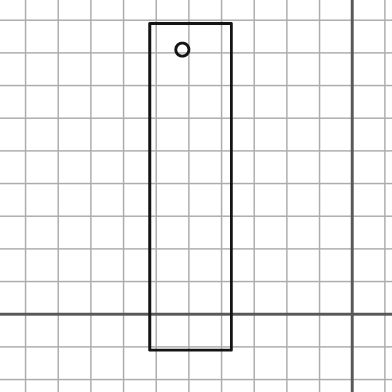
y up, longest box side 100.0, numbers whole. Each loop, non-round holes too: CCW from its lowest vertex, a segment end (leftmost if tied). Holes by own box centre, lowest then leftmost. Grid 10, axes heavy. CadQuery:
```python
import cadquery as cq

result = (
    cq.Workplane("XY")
    .moveTo(-62.0, -11.0)
    .lineTo(-37.0, -11.0)
    .lineTo(-37.0, 89.0)
    .lineTo(-62.0, 89.0)
    .close()
    .moveTo(-52.0, 81.0)
    .circle(2.0)
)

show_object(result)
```